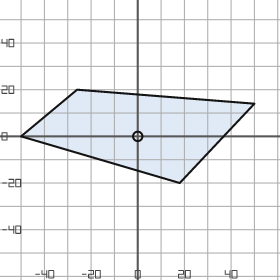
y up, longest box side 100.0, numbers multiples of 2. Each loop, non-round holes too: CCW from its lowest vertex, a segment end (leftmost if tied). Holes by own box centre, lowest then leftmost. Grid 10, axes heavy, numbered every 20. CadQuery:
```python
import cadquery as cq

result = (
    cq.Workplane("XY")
    .moveTo(18.0, -20.0)
    .lineTo(50.0, 14.0)
    .lineTo(-26.0, 20.0)
    .lineTo(-50.0, 0.0)
    .close()
    .moveTo(0.0, 0.0)
    .circle(2.0)
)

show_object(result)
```